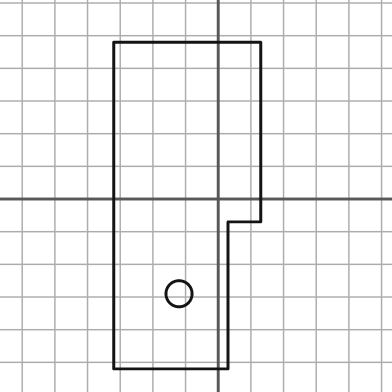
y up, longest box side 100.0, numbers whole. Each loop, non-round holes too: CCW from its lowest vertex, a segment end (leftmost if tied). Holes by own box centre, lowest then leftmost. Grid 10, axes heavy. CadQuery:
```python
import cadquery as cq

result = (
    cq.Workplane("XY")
    .moveTo(-32.0, -52.0)
    .lineTo(3.0, -52.0)
    .lineTo(3.0, -7.0)
    .lineTo(13.0, -7.0)
    .lineTo(13.0, 48.0)
    .lineTo(-32.0, 48.0)
    .close()
    .moveTo(-12.0, -29.0)
    .circle(4.0)
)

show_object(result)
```